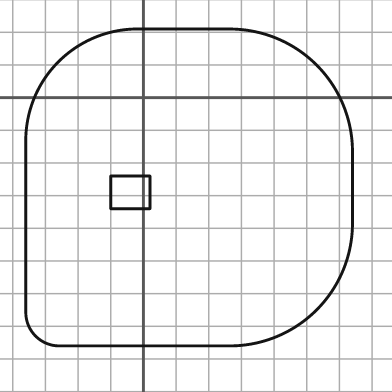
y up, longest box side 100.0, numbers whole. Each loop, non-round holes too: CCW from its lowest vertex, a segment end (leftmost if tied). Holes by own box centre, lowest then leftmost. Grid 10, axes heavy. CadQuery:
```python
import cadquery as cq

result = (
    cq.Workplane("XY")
    .moveTo(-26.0, -76.0)
    .lineTo(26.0, -76.0)
    .threePointArc((53.0, -65.0), (64.0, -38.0))
    .lineTo(64.0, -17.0)
    .threePointArc((53.0, 10.0), (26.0, 21.0))
    .lineTo(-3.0, 21.0)
    .threePointArc((-26.0, 11.0), (-36.0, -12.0))
    .lineTo(-36.0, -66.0)
    .threePointArc((-33.0, -73.0), (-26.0, -76.0))
    .close()
    .moveTo(-10.0, -34.0)
    .lineTo(2.0, -34.0)
    .lineTo(2.0, -24.0)
    .lineTo(-10.0, -24.0)
    .close()
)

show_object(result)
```